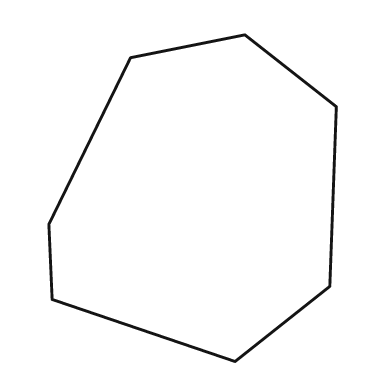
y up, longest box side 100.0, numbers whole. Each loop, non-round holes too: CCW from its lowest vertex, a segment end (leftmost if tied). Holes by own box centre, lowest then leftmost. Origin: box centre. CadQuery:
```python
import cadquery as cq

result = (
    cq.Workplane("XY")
    .moveTo(13.0, -50.0)
    .lineTo(42.0, -27.0)
    .lineTo(44.0, 28.0)
    .lineTo(16.0, 50.0)
    .lineTo(-19.0, 43.0)
    .lineTo(-44.0, -8.0)
    .lineTo(-43.0, -31.0)
    .close()
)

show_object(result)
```